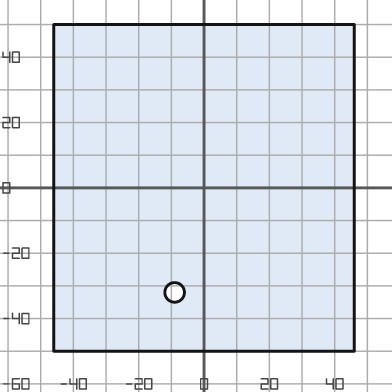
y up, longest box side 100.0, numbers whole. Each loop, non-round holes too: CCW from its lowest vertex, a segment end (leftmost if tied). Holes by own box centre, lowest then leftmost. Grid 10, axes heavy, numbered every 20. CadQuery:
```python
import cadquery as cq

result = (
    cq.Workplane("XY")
    .moveTo(-46.0, -50.0)
    .lineTo(46.0, -50.0)
    .lineTo(46.0, 50.0)
    .lineTo(-46.0, 50.0)
    .close()
    .moveTo(-9.0, -32.0)
    .circle(3.0)
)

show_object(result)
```